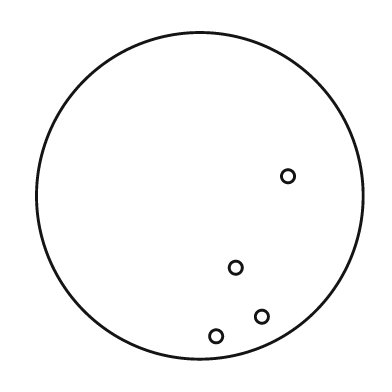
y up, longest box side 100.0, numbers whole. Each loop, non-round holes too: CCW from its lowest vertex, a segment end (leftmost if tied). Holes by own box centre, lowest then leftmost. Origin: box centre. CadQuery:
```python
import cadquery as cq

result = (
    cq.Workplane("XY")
    .moveTo(0.0, 0.0)
    .circle(50.0)
    .moveTo(5.0, -43.0)
    .circle(2.0)
    .moveTo(19.0, -37.0)
    .circle(2.0)
    .moveTo(11.0, -22.0)
    .circle(2.0)
    .moveTo(27.0, 6.0)
    .circle(2.0)
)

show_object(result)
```